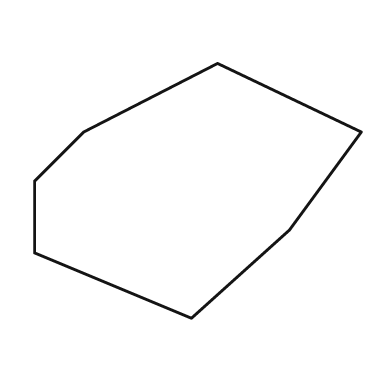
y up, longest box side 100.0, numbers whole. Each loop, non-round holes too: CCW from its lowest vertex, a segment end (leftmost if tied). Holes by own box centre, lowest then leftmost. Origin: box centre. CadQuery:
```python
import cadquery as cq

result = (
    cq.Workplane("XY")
    .moveTo(-2.0, -39.0)
    .lineTo(28.0, -12.0)
    .lineTo(50.0, 18.0)
    .lineTo(6.0, 39.0)
    .lineTo(-35.0, 18.0)
    .lineTo(-50.0, 3.0)
    .lineTo(-50.0, -19.0)
    .close()
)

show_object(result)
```